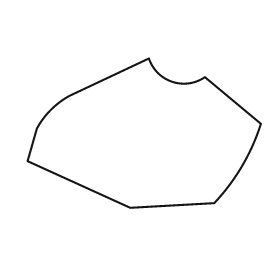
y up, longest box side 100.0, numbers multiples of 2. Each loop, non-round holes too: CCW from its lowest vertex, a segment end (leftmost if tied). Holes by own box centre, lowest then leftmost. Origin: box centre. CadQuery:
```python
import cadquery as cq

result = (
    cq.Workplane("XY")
    .moveTo(-6.0, -32.0)
    .lineTo(30.0, -30.0)
    .threePointArc((42.0, -14.0), (50.0, 4.0))
    .lineTo(26.0, 24.0)
    .threePointArc((12.0, 22.0), (2.0, 32.0))
    .lineTo(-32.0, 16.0)
    .threePointArc((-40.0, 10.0), (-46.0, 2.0))
    .lineTo(-50.0, -12.0)
    .close()
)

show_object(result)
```